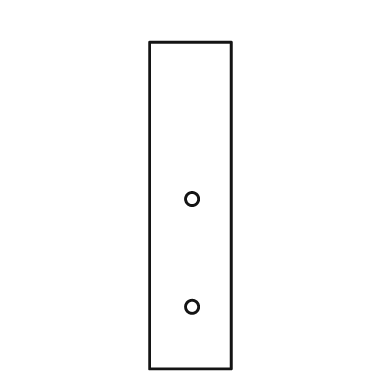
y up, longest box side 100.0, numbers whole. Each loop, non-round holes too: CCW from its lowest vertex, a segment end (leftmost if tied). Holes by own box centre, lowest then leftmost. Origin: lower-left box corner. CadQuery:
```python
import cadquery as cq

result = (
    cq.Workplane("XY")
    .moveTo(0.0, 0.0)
    .lineTo(25.0, 0.0)
    .lineTo(25.0, 100.0)
    .lineTo(0.0, 100.0)
    .close()
    .moveTo(13.0, 19.0)
    .circle(2.0)
    .moveTo(13.0, 52.0)
    .circle(2.0)
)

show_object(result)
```